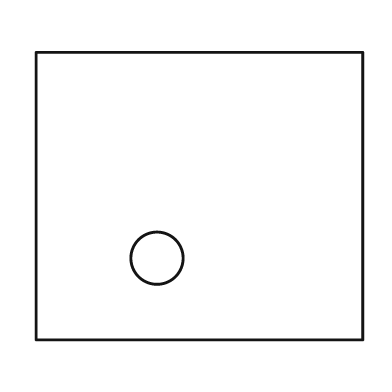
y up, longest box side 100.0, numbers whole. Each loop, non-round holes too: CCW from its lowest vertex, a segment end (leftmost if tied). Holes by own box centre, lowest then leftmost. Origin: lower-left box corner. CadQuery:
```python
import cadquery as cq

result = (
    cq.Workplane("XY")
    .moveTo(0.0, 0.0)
    .lineTo(100.0, 0.0)
    .lineTo(100.0, 88.0)
    .lineTo(0.0, 88.0)
    .close()
    .moveTo(37.0, 25.0)
    .circle(8.0)
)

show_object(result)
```